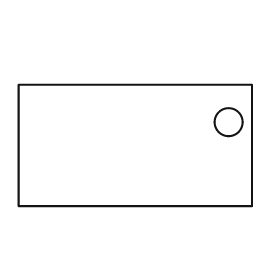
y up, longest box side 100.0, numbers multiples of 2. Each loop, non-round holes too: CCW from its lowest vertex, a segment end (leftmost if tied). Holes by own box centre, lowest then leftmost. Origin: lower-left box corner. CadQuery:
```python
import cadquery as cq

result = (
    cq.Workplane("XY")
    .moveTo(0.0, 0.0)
    .lineTo(100.0, 0.0)
    .lineTo(100.0, 52.0)
    .lineTo(0.0, 52.0)
    .close()
    .moveTo(90.0, 36.0)
    .circle(6.0)
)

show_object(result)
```